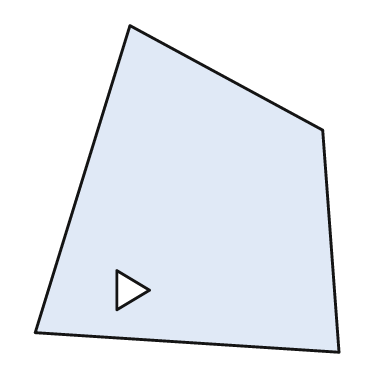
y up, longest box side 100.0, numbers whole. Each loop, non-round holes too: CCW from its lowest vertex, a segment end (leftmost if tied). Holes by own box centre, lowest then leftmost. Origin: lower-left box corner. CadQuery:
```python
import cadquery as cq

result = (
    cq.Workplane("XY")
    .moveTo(93.0, 0.0)
    .lineTo(88.0, 68.0)
    .lineTo(29.0, 100.0)
    .lineTo(0.0, 6.0)
    .close()
    .moveTo(25.0, 13.0)
    .lineTo(35.0, 19.0)
    .lineTo(25.0, 25.0)
    .close()
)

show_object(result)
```